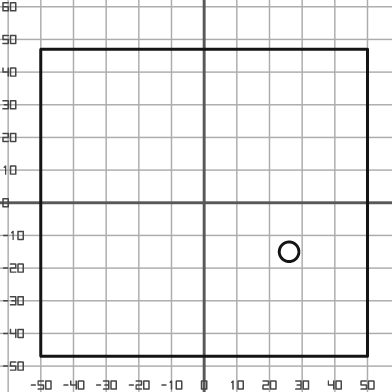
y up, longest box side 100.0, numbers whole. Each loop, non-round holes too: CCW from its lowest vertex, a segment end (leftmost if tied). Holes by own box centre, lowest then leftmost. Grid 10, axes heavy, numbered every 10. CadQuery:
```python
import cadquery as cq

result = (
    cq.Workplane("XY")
    .moveTo(-50.0, -47.0)
    .lineTo(50.0, -47.0)
    .lineTo(50.0, 47.0)
    .lineTo(-50.0, 47.0)
    .close()
    .moveTo(26.0, -15.0)
    .circle(3.0)
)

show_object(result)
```